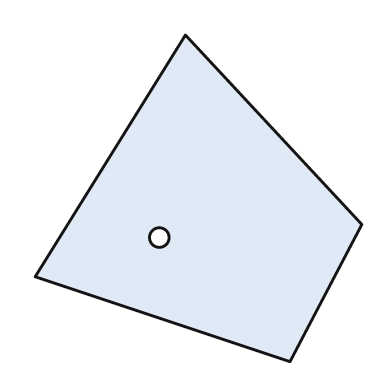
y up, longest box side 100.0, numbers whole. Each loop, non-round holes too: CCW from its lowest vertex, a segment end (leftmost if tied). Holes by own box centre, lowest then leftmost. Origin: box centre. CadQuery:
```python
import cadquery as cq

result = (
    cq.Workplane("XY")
    .moveTo(28.0, -50.0)
    .lineTo(50.0, -8.0)
    .lineTo(-4.0, 50.0)
    .lineTo(-50.0, -24.0)
    .close()
    .moveTo(-12.0, -12.0)
    .circle(3.0)
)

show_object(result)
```